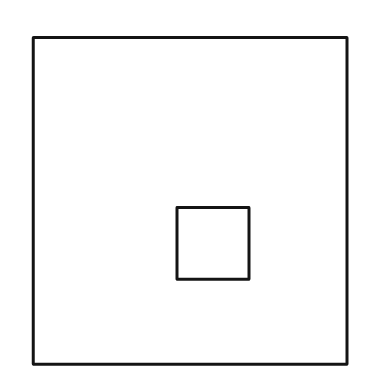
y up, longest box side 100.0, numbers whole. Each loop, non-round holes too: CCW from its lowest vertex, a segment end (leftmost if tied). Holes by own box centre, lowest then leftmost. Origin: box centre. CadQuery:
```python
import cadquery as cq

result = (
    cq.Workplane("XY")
    .moveTo(-48.0, -50.0)
    .lineTo(48.0, -50.0)
    .lineTo(48.0, 50.0)
    .lineTo(-48.0, 50.0)
    .close()
    .moveTo(-4.0, -24.0)
    .lineTo(18.0, -24.0)
    .lineTo(18.0, -2.0)
    .lineTo(-4.0, -2.0)
    .close()
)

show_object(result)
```